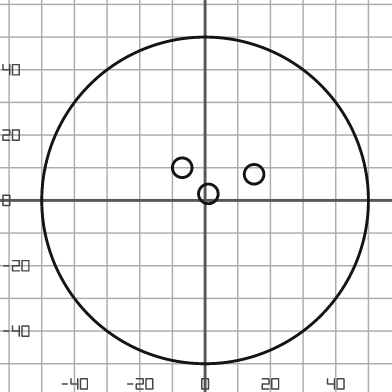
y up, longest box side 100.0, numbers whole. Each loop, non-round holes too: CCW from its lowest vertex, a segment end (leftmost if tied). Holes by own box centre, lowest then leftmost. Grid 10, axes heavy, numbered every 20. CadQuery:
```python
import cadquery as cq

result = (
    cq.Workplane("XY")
    .moveTo(0.0, 0.0)
    .circle(50.0)
    .moveTo(1.0, 2.0)
    .circle(3.0)
    .moveTo(15.0, 8.0)
    .circle(3.0)
    .moveTo(-7.0, 10.0)
    .circle(3.0)
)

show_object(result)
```